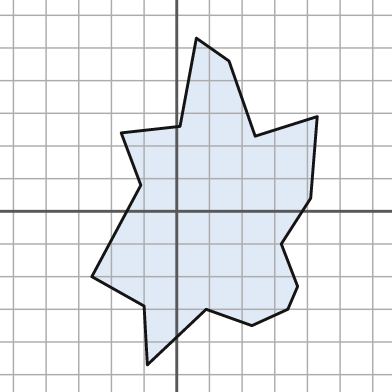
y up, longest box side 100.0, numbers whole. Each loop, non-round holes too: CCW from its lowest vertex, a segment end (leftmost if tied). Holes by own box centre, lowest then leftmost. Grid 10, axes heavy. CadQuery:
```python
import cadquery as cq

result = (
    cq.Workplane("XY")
    .moveTo(-9.0, -47.0)
    .lineTo(9.0, -30.0)
    .lineTo(23.0, -35.0)
    .lineTo(34.0, -30.0)
    .lineTo(37.0, -23.0)
    .lineTo(32.0, -10.0)
    .lineTo(41.0, 4.0)
    .lineTo(43.0, 29.0)
    .lineTo(24.0, 23.0)
    .lineTo(16.0, 46.0)
    .lineTo(6.0, 53.0)
    .lineTo(1.0, 26.0)
    .lineTo(-17.0, 24.0)
    .lineTo(-11.0, 8.0)
    .lineTo(-26.0, -20.0)
    .lineTo(-10.0, -29.0)
    .close()
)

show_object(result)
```